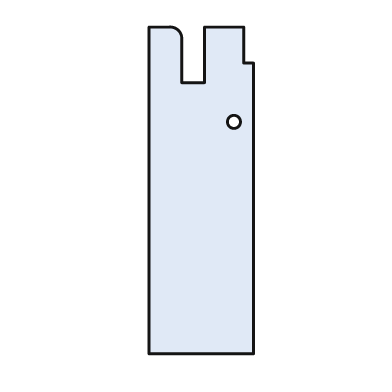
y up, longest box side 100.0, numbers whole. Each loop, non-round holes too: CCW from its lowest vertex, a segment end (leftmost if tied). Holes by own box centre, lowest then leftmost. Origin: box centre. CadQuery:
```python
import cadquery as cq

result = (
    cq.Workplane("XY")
    .moveTo(-16.0, -50.0)
    .lineTo(16.0, -50.0)
    .lineTo(16.0, 39.0)
    .lineTo(13.0, 39.0)
    .lineTo(13.0, 50.0)
    .lineTo(1.0, 50.0)
    .lineTo(1.0, 33.0)
    .lineTo(-6.0, 33.0)
    .lineTo(-6.0, 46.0)
    .threePointArc((-7.0, 49.0), (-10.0, 50.0))
    .lineTo(-16.0, 50.0)
    .close()
    .moveTo(10.0, 21.0)
    .circle(2.0)
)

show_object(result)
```